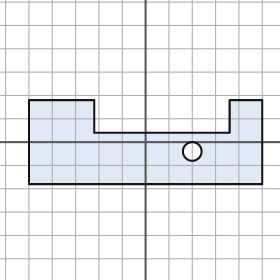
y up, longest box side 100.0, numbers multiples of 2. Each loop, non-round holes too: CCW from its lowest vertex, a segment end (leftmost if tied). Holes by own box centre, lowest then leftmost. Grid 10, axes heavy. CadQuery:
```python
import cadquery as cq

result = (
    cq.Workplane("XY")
    .moveTo(-50.0, -18.0)
    .lineTo(50.0, -18.0)
    .lineTo(50.0, 18.0)
    .lineTo(36.0, 18.0)
    .lineTo(36.0, 4.0)
    .lineTo(-22.0, 4.0)
    .lineTo(-22.0, 18.0)
    .lineTo(-50.0, 18.0)
    .close()
    .moveTo(20.0, -4.0)
    .circle(4.0)
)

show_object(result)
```